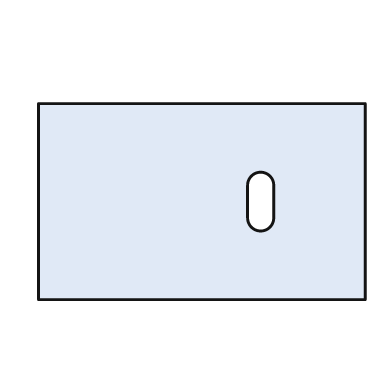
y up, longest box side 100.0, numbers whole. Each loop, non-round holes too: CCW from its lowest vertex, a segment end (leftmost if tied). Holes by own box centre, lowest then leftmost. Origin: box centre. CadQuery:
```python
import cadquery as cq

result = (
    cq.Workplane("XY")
    .moveTo(-50.0, -30.0)
    .lineTo(50.0, -30.0)
    .lineTo(50.0, 30.0)
    .lineTo(-50.0, 30.0)
    .close()
    .moveTo(14.0, -5.0)
    .threePointArc((18.0, -9.0), (22.0, -5.0))
    .lineTo(22.0, 5.0)
    .threePointArc((18.0, 9.0), (14.0, 5.0))
    .close()
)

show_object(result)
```